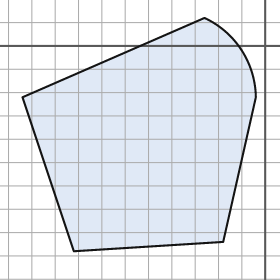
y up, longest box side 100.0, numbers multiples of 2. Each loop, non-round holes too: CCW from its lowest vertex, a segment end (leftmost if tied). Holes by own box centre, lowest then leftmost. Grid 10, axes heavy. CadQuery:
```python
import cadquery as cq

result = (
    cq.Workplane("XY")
    .moveTo(-82.0, -88.0)
    .lineTo(-18.0, -84.0)
    .lineTo(-4.0, -22.0)
    .threePointArc((-10.0, -2.0), (-26.0, 12.0))
    .lineTo(-104.0, -22.0)
    .close()
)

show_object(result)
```